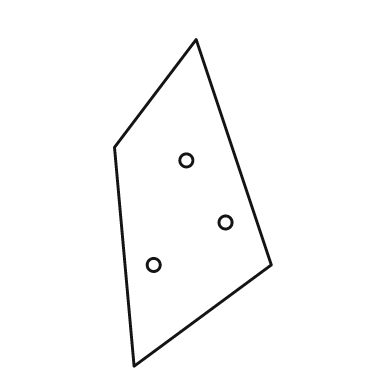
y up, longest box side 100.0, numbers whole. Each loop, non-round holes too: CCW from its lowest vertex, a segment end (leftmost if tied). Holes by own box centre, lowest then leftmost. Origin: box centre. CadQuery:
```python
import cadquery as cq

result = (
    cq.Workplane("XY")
    .moveTo(-18.0, -50.0)
    .lineTo(24.0, -19.0)
    .lineTo(1.0, 50.0)
    .lineTo(-24.0, 17.0)
    .close()
    .moveTo(-12.0, -19.0)
    .circle(2.0)
    .moveTo(10.0, -6.0)
    .circle(2.0)
    .moveTo(-2.0, 13.0)
    .circle(2.0)
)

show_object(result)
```